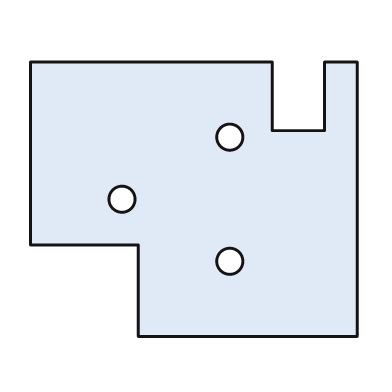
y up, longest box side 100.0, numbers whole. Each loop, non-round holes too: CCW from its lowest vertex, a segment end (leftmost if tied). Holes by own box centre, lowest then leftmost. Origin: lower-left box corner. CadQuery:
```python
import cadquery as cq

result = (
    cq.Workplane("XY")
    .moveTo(33.0, 0.0)
    .lineTo(100.0, 0.0)
    .lineTo(100.0, 84.0)
    .lineTo(90.0, 84.0)
    .lineTo(90.0, 63.0)
    .lineTo(74.0, 63.0)
    .lineTo(74.0, 84.0)
    .lineTo(0.0, 84.0)
    .lineTo(0.0, 28.0)
    .lineTo(33.0, 28.0)
    .close()
    .moveTo(61.0, 23.0)
    .circle(4.0)
    .moveTo(28.0, 42.0)
    .circle(4.0)
    .moveTo(61.0, 61.0)
    .circle(4.0)
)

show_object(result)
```